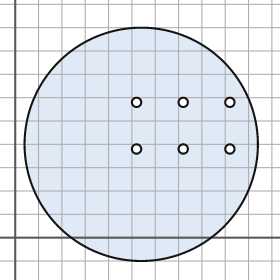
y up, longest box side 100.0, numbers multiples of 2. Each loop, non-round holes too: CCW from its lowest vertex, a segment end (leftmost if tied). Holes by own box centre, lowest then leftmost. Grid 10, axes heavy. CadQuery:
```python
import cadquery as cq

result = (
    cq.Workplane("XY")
    .moveTo(54.0, 40.0)
    .circle(50.0)
    .moveTo(52.0, 38.0)
    .circle(2.0)
    .moveTo(72.0, 38.0)
    .circle(2.0)
    .moveTo(92.0, 38.0)
    .circle(2.0)
    .moveTo(52.0, 58.0)
    .circle(2.0)
    .moveTo(72.0, 58.0)
    .circle(2.0)
    .moveTo(92.0, 58.0)
    .circle(2.0)
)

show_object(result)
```